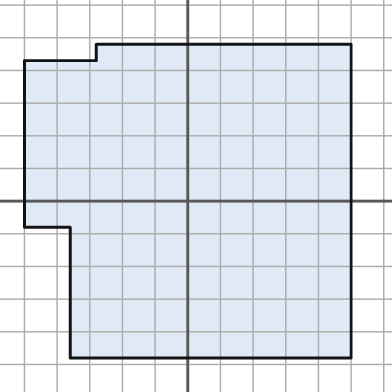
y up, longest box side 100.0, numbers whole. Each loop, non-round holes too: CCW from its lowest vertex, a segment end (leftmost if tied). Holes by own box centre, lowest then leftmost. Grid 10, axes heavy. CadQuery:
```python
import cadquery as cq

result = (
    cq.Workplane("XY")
    .moveTo(-36.0, -48.0)
    .lineTo(50.0, -48.0)
    .lineTo(50.0, 48.0)
    .lineTo(-28.0, 48.0)
    .lineTo(-28.0, 43.0)
    .lineTo(-50.0, 43.0)
    .lineTo(-50.0, -8.0)
    .lineTo(-36.0, -8.0)
    .close()
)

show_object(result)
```